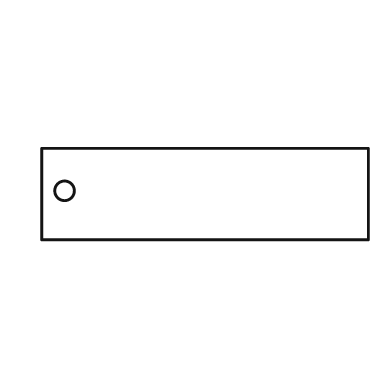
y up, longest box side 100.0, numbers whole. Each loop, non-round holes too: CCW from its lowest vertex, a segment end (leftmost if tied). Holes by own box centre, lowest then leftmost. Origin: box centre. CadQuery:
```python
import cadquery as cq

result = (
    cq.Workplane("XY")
    .moveTo(-50.0, -14.0)
    .lineTo(50.0, -14.0)
    .lineTo(50.0, 14.0)
    .lineTo(-50.0, 14.0)
    .close()
    .moveTo(-43.0, 1.0)
    .circle(3.0)
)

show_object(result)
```